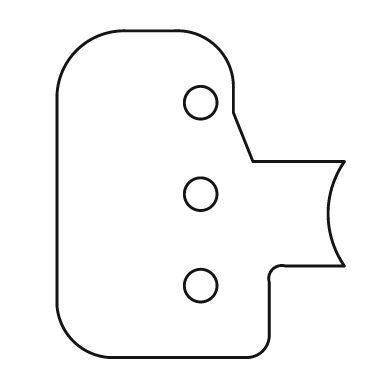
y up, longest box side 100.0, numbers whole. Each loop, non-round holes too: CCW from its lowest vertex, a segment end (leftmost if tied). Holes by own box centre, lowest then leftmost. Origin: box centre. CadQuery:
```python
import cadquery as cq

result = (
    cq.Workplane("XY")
    .moveTo(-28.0, -50.0)
    .lineTo(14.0, -50.0)
    .threePointArc((19.0, -48.0), (21.0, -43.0))
    .lineTo(21.0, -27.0)
    .threePointArc((22.0, -23.0), (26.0, -22.0))
    .lineTo(44.0, -22.0)
    .threePointArc((39.0, -6.0), (44.0, 10.0))
    .lineTo(16.0, 10.0)
    .lineTo(10.0, 25.0)
    .lineTo(10.0, 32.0)
    .threePointArc((5.0, 45.0), (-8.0, 50.0))
    .lineTo(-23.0, 50.0)
    .threePointArc((-38.0, 44.0), (-44.0, 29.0))
    .lineTo(-44.0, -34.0)
    .threePointArc((-39.0, -45.0), (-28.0, -50.0))
    .close()
    .moveTo(0.0, -28.0)
    .circle(5.0)
    .moveTo(0.0, 0.0)
    .circle(5.0)
    .moveTo(0.0, 28.0)
    .circle(5.0)
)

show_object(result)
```